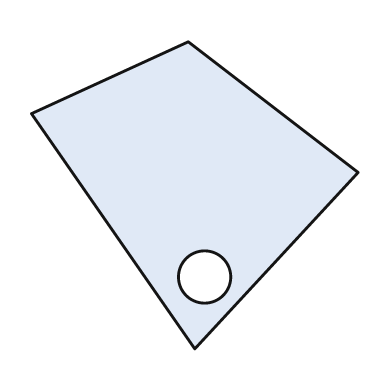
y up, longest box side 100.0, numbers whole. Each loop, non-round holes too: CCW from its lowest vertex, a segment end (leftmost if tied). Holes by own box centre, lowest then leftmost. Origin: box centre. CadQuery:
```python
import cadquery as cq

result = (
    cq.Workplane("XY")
    .moveTo(0.0, -47.0)
    .lineTo(50.0, 7.0)
    .lineTo(-2.0, 47.0)
    .lineTo(-50.0, 25.0)
    .close()
    .moveTo(3.0, -25.0)
    .circle(8.0)
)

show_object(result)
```